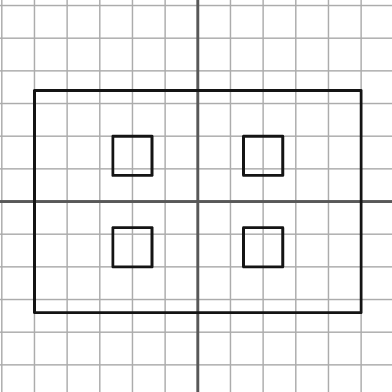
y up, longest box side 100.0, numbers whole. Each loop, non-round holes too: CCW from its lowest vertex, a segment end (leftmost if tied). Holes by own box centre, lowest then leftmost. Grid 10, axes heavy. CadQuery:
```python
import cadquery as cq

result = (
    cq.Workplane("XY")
    .moveTo(-50.0, -34.0)
    .lineTo(50.0, -34.0)
    .lineTo(50.0, 34.0)
    .lineTo(-50.0, 34.0)
    .close()
    .moveTo(-26.0, -20.0)
    .lineTo(-14.0, -20.0)
    .lineTo(-14.0, -8.0)
    .lineTo(-26.0, -8.0)
    .close()
    .moveTo(14.0, -20.0)
    .lineTo(26.0, -20.0)
    .lineTo(26.0, -8.0)
    .lineTo(14.0, -8.0)
    .close()
    .moveTo(-26.0, 8.0)
    .lineTo(-14.0, 8.0)
    .lineTo(-14.0, 20.0)
    .lineTo(-26.0, 20.0)
    .close()
    .moveTo(14.0, 8.0)
    .lineTo(26.0, 8.0)
    .lineTo(26.0, 20.0)
    .lineTo(14.0, 20.0)
    .close()
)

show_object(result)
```